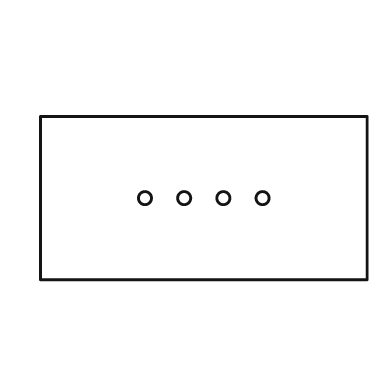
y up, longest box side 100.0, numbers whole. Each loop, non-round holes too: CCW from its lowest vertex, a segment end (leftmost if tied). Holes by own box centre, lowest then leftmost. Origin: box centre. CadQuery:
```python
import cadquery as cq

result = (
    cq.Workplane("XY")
    .moveTo(-50.0, -25.0)
    .lineTo(50.0, -25.0)
    .lineTo(50.0, 25.0)
    .lineTo(-50.0, 25.0)
    .close()
    .moveTo(-18.0, 0.0)
    .circle(2.0)
    .moveTo(-6.0, 0.0)
    .circle(2.0)
    .moveTo(6.0, 0.0)
    .circle(2.0)
    .moveTo(18.0, 0.0)
    .circle(2.0)
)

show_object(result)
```